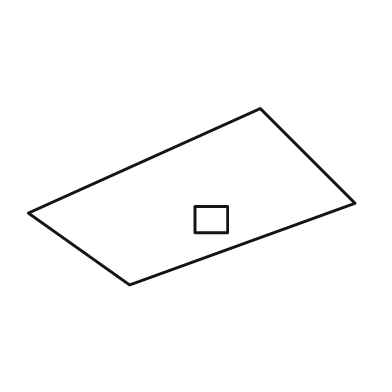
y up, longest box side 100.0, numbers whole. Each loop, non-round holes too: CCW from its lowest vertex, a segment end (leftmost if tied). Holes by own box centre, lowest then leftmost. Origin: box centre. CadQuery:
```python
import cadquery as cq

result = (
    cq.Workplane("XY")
    .moveTo(-19.0, -27.0)
    .lineTo(50.0, -2.0)
    .lineTo(21.0, 27.0)
    .lineTo(-50.0, -5.0)
    .close()
    .moveTo(1.0, -11.0)
    .lineTo(11.0, -11.0)
    .lineTo(11.0, -3.0)
    .lineTo(1.0, -3.0)
    .close()
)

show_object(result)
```